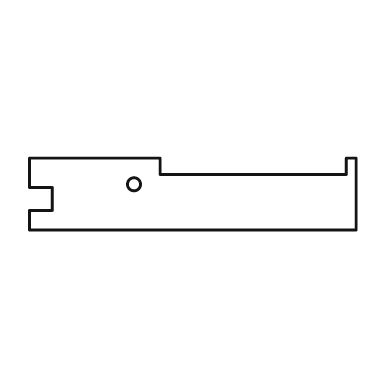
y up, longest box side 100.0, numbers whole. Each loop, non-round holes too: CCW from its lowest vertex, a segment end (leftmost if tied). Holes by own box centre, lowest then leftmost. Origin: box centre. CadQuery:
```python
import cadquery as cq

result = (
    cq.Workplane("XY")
    .moveTo(-50.0, -11.0)
    .lineTo(50.0, -11.0)
    .lineTo(50.0, 11.0)
    .lineTo(47.0, 11.0)
    .lineTo(47.0, 6.0)
    .lineTo(-10.0, 6.0)
    .lineTo(-10.0, 11.0)
    .lineTo(-50.0, 11.0)
    .lineTo(-50.0, 2.0)
    .lineTo(-43.0, 2.0)
    .lineTo(-43.0, -5.0)
    .lineTo(-50.0, -5.0)
    .close()
    .moveTo(-18.0, 3.0)
    .circle(2.0)
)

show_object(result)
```